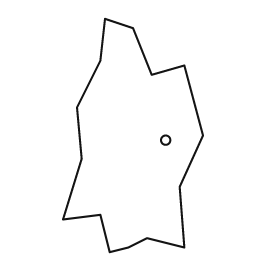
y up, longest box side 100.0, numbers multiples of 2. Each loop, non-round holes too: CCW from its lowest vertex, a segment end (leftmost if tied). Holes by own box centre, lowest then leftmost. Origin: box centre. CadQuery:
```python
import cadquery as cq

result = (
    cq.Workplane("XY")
    .moveTo(-10.0, -50.0)
    .lineTo(-2.0, -48.0)
    .lineTo(6.0, -44.0)
    .lineTo(22.0, -48.0)
    .lineTo(20.0, -22.0)
    .lineTo(30.0, 0.0)
    .lineTo(22.0, 30.0)
    .lineTo(8.0, 26.0)
    .lineTo(0.0, 46.0)
    .lineTo(-12.0, 50.0)
    .lineTo(-14.0, 32.0)
    .lineTo(-24.0, 12.0)
    .lineTo(-22.0, -10.0)
    .lineTo(-30.0, -36.0)
    .lineTo(-14.0, -34.0)
    .close()
    .moveTo(14.0, -2.0)
    .circle(2.0)
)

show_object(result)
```